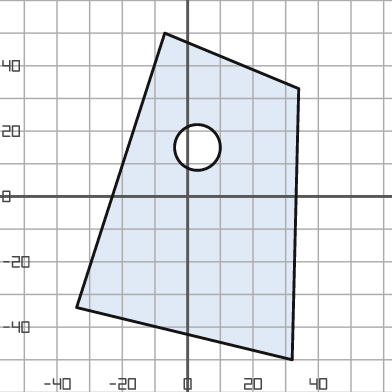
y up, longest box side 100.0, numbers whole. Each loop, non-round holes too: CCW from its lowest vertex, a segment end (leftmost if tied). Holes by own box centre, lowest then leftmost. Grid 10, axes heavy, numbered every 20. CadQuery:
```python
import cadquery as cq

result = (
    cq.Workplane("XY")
    .moveTo(32.0, -50.0)
    .lineTo(34.0, 33.0)
    .lineTo(-7.0, 50.0)
    .lineTo(-34.0, -34.0)
    .close()
    .moveTo(3.0, 15.0)
    .circle(7.0)
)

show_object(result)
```